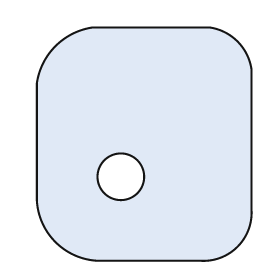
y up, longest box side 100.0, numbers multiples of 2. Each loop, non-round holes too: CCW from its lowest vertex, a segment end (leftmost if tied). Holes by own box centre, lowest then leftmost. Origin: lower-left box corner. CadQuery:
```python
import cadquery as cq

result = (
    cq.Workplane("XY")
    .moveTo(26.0, 0.0)
    .lineTo(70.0, 0.0)
    .threePointArc((86.0, 6.0), (92.0, 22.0))
    .lineTo(92.0, 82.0)
    .threePointArc((86.0, 94.0), (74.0, 100.0))
    .lineTo(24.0, 100.0)
    .threePointArc((8.0, 92.0), (0.0, 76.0))
    .lineTo(0.0, 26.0)
    .threePointArc((8.0, 8.0), (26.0, 0.0))
    .close()
    .moveTo(36.0, 36.0)
    .circle(10.0)
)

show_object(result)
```